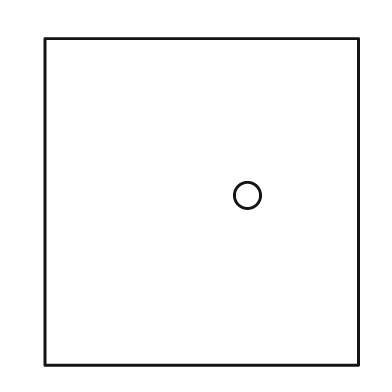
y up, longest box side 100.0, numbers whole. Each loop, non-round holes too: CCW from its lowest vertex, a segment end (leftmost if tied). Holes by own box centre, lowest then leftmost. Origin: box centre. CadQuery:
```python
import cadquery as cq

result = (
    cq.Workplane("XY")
    .moveTo(-48.0, -50.0)
    .lineTo(48.0, -50.0)
    .lineTo(48.0, 50.0)
    .lineTo(-48.0, 50.0)
    .close()
    .moveTo(14.0, 2.0)
    .circle(4.0)
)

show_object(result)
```